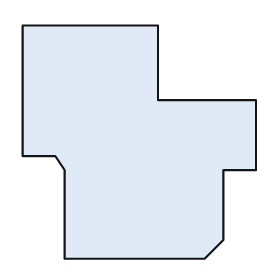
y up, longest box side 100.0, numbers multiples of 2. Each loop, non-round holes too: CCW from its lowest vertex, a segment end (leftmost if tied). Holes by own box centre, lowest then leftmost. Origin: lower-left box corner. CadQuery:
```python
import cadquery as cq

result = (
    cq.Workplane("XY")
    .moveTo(18.0, 0.0)
    .lineTo(78.0, 0.0)
    .lineTo(86.0, 8.0)
    .lineTo(86.0, 38.0)
    .lineTo(100.0, 38.0)
    .lineTo(100.0, 68.0)
    .lineTo(58.0, 68.0)
    .lineTo(58.0, 100.0)
    .lineTo(0.0, 100.0)
    .lineTo(0.0, 44.0)
    .lineTo(14.0, 44.0)
    .lineTo(18.0, 38.0)
    .close()
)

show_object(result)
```